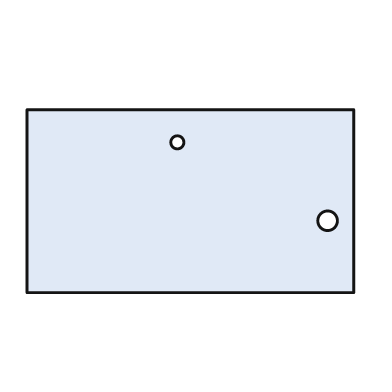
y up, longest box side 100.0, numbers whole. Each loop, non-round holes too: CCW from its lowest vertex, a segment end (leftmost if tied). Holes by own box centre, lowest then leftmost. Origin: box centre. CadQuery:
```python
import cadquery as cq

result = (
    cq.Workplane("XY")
    .moveTo(-50.0, -28.0)
    .lineTo(50.0, -28.0)
    .lineTo(50.0, 28.0)
    .lineTo(-50.0, 28.0)
    .close()
    .moveTo(42.0, -6.0)
    .circle(3.0)
    .moveTo(-4.0, 18.0)
    .circle(2.0)
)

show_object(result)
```